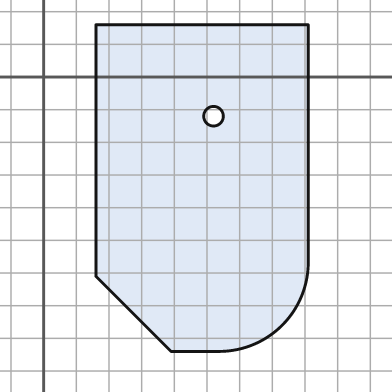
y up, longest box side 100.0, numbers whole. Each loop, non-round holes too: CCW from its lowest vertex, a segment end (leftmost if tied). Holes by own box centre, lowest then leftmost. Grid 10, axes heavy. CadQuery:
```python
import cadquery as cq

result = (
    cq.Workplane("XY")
    .moveTo(39.0, -84.0)
    .lineTo(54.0, -84.0)
    .threePointArc((73.0, -76.0), (81.0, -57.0))
    .lineTo(81.0, 16.0)
    .lineTo(16.0, 16.0)
    .lineTo(16.0, -61.0)
    .close()
    .moveTo(52.0, -12.0)
    .circle(3.0)
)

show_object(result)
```